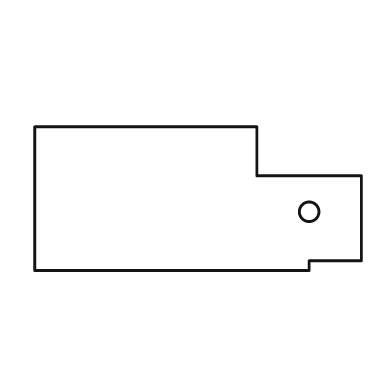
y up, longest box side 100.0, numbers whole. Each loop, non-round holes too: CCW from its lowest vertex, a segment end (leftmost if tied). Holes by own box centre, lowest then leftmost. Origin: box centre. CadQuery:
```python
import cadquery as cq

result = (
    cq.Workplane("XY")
    .moveTo(-50.0, -22.0)
    .lineTo(34.0, -22.0)
    .lineTo(34.0, -19.0)
    .lineTo(50.0, -19.0)
    .lineTo(50.0, 7.0)
    .lineTo(18.0, 7.0)
    .lineTo(18.0, 22.0)
    .lineTo(-50.0, 22.0)
    .close()
    .moveTo(34.0, -4.0)
    .circle(3.0)
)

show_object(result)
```